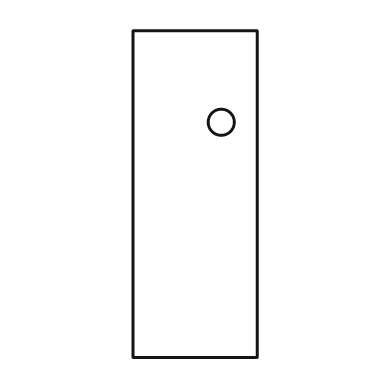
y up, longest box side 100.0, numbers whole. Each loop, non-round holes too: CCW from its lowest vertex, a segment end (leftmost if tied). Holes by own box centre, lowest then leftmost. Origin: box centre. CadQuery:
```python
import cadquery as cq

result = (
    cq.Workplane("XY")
    .moveTo(-19.0, -50.0)
    .lineTo(19.0, -50.0)
    .lineTo(19.0, 50.0)
    .lineTo(-19.0, 50.0)
    .close()
    .moveTo(8.0, 22.0)
    .circle(4.0)
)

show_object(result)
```